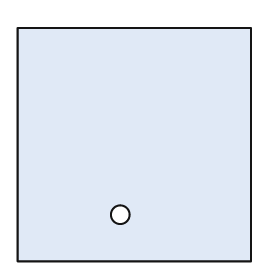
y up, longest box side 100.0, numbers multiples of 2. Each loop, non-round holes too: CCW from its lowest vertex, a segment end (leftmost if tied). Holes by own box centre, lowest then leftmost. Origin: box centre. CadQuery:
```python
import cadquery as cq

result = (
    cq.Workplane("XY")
    .moveTo(-50.0, -50.0)
    .lineTo(50.0, -50.0)
    .lineTo(50.0, 50.0)
    .lineTo(-50.0, 50.0)
    .close()
    .moveTo(-6.0, -30.0)
    .circle(4.0)
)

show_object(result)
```